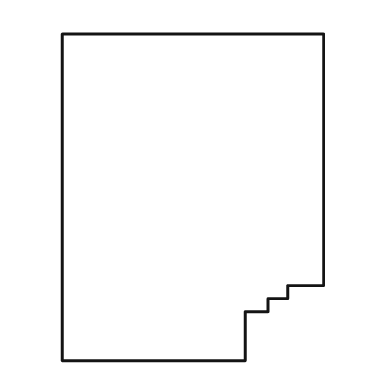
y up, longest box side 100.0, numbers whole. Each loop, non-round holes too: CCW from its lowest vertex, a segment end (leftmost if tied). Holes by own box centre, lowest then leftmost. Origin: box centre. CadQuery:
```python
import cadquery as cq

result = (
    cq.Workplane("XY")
    .moveTo(-40.0, -50.0)
    .lineTo(16.0, -50.0)
    .lineTo(16.0, -35.0)
    .lineTo(23.0, -35.0)
    .lineTo(23.0, -31.0)
    .lineTo(29.0, -31.0)
    .lineTo(29.0, -27.0)
    .lineTo(40.0, -27.0)
    .lineTo(40.0, 50.0)
    .lineTo(-40.0, 50.0)
    .close()
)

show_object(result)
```